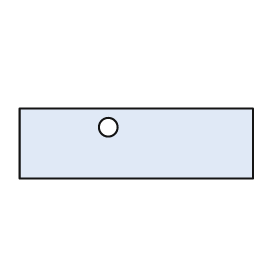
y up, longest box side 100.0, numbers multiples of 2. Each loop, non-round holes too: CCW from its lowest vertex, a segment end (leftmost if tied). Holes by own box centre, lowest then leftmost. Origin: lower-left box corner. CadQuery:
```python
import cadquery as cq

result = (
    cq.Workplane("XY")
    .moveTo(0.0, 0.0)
    .lineTo(100.0, 0.0)
    .lineTo(100.0, 30.0)
    .lineTo(0.0, 30.0)
    .close()
    .moveTo(38.0, 22.0)
    .circle(4.0)
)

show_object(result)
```